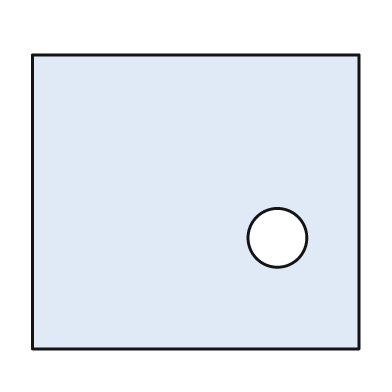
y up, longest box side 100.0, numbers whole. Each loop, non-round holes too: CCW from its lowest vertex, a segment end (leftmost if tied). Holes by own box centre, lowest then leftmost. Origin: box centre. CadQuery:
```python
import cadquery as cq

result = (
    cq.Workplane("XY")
    .moveTo(-50.0, -45.0)
    .lineTo(50.0, -45.0)
    .lineTo(50.0, 45.0)
    .lineTo(-50.0, 45.0)
    .close()
    .moveTo(25.0, -11.0)
    .circle(9.0)
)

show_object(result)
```